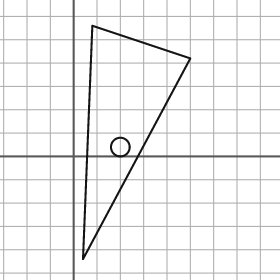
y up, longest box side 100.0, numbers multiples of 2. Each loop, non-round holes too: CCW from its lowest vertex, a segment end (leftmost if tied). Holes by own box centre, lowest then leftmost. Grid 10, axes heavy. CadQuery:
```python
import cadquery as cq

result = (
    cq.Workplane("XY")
    .moveTo(4.0, -44.0)
    .lineTo(50.0, 42.0)
    .lineTo(8.0, 56.0)
    .close()
    .moveTo(20.0, 4.0)
    .circle(4.0)
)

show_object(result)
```